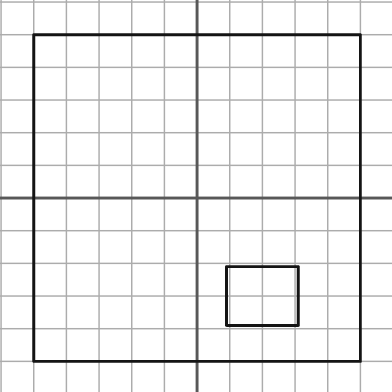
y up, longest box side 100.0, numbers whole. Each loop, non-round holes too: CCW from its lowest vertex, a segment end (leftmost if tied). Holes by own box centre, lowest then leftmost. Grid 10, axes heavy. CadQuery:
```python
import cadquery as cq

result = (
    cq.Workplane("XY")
    .moveTo(-50.0, -50.0)
    .lineTo(50.0, -50.0)
    .lineTo(50.0, 50.0)
    .lineTo(-50.0, 50.0)
    .close()
    .moveTo(9.0, -39.0)
    .lineTo(31.0, -39.0)
    .lineTo(31.0, -21.0)
    .lineTo(9.0, -21.0)
    .close()
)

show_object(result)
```